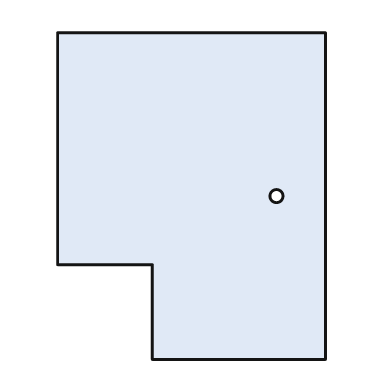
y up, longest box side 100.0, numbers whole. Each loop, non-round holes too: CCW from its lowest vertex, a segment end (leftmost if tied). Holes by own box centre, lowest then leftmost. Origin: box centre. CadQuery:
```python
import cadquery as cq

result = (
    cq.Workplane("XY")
    .moveTo(-12.0, -50.0)
    .lineTo(41.0, -50.0)
    .lineTo(41.0, 50.0)
    .lineTo(-41.0, 50.0)
    .lineTo(-41.0, -21.0)
    .lineTo(-12.0, -21.0)
    .close()
    .moveTo(26.0, 0.0)
    .circle(2.0)
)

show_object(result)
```